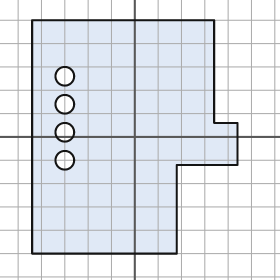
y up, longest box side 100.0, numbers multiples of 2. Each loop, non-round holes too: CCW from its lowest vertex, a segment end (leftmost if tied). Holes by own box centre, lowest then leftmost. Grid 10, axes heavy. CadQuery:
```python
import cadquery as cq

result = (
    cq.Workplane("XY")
    .moveTo(-44.0, -50.0)
    .lineTo(18.0, -50.0)
    .lineTo(18.0, -12.0)
    .lineTo(44.0, -12.0)
    .lineTo(44.0, 6.0)
    .lineTo(34.0, 6.0)
    .lineTo(34.0, 50.0)
    .lineTo(-44.0, 50.0)
    .close()
    .moveTo(-30.0, -10.0)
    .circle(4.0)
    .moveTo(-30.0, 2.0)
    .circle(4.0)
    .moveTo(-30.0, 14.0)
    .circle(4.0)
    .moveTo(-30.0, 26.0)
    .circle(4.0)
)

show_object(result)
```